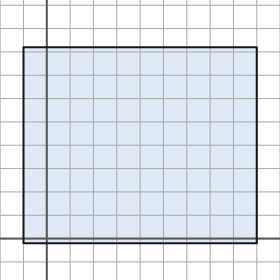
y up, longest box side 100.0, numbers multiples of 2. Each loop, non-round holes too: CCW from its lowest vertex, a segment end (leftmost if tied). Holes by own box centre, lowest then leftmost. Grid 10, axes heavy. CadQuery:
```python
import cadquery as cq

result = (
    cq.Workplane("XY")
    .moveTo(-10.0, -2.0)
    .lineTo(90.0, -2.0)
    .lineTo(90.0, 82.0)
    .lineTo(-10.0, 82.0)
    .close()
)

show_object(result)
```